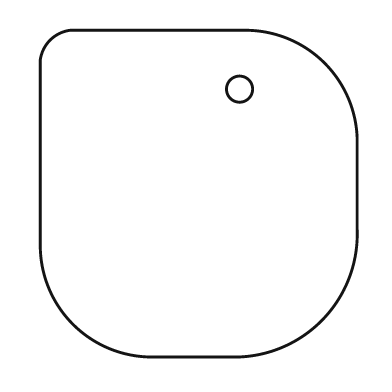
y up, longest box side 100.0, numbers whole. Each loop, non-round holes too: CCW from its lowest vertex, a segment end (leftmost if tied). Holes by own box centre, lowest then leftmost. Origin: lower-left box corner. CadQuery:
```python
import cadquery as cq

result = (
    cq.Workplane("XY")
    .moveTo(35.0, 0.0)
    .lineTo(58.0, 0.0)
    .threePointArc((86.0, 11.0), (97.0, 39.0))
    .lineTo(97.0, 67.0)
    .threePointArc((87.0, 90.0), (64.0, 100.0))
    .lineTo(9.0, 100.0)
    .threePointArc((3.0, 97.0), (0.0, 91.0))
    .lineTo(0.0, 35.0)
    .threePointArc((10.0, 10.0), (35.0, 0.0))
    .close()
    .moveTo(61.0, 82.0)
    .circle(4.0)
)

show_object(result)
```